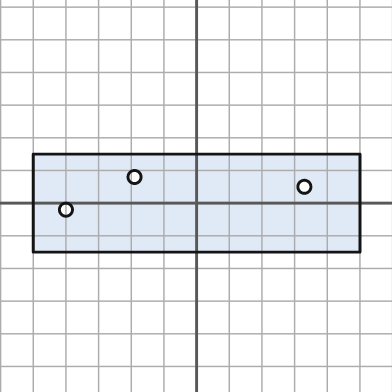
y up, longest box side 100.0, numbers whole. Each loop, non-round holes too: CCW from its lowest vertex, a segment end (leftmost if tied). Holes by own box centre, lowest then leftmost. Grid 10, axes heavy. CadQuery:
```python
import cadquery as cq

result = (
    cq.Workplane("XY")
    .moveTo(-50.0, -15.0)
    .lineTo(50.0, -15.0)
    .lineTo(50.0, 15.0)
    .lineTo(-50.0, 15.0)
    .close()
    .moveTo(-40.0, -2.0)
    .circle(2.0)
    .moveTo(33.0, 5.0)
    .circle(2.0)
    .moveTo(-19.0, 8.0)
    .circle(2.0)
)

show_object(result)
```